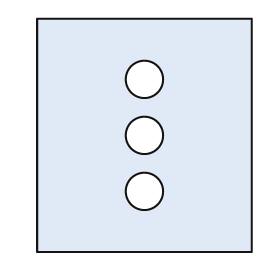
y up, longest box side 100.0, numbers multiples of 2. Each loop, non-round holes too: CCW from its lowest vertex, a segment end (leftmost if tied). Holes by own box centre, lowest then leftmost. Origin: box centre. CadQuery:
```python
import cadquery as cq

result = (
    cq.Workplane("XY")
    .moveTo(-46.0, -50.0)
    .lineTo(46.0, -50.0)
    .lineTo(46.0, 50.0)
    .lineTo(-46.0, 50.0)
    .close()
    .moveTo(0.0, -24.0)
    .circle(8.0)
    .moveTo(0.0, 0.0)
    .circle(8.0)
    .moveTo(0.0, 24.0)
    .circle(8.0)
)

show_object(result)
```